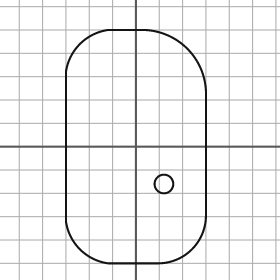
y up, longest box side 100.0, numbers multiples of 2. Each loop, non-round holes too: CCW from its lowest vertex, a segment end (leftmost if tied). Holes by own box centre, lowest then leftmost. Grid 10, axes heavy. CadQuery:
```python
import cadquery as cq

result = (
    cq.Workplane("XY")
    .moveTo(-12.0, -50.0)
    .lineTo(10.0, -50.0)
    .threePointArc((24.0, -44.0), (30.0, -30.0))
    .lineTo(30.0, 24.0)
    .threePointArc((22.0, 42.0), (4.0, 50.0))
    .lineTo(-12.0, 50.0)
    .threePointArc((-24.0, 44.0), (-30.0, 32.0))
    .lineTo(-30.0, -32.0)
    .threePointArc((-24.0, -44.0), (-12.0, -50.0))
    .close()
    .moveTo(12.0, -16.0)
    .circle(4.0)
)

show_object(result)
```